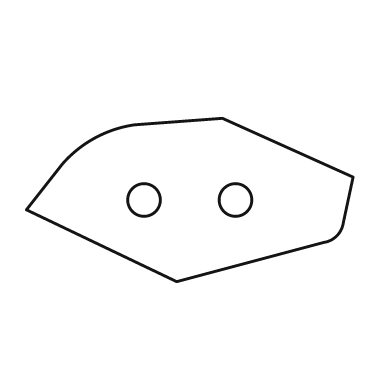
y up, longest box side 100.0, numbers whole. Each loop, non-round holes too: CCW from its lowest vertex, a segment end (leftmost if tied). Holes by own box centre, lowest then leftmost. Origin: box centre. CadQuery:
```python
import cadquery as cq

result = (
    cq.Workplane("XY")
    .moveTo(-4.0, -25.0)
    .lineTo(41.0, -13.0)
    .threePointArc((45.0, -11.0), (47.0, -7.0))
    .lineTo(50.0, 7.0)
    .lineTo(10.0, 25.0)
    .lineTo(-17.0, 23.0)
    .threePointArc((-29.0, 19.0), (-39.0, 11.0))
    .lineTo(-50.0, -3.0)
    .close()
    .moveTo(-14.0, 0.0)
    .circle(5.0)
    .moveTo(14.0, 0.0)
    .circle(5.0)
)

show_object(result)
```